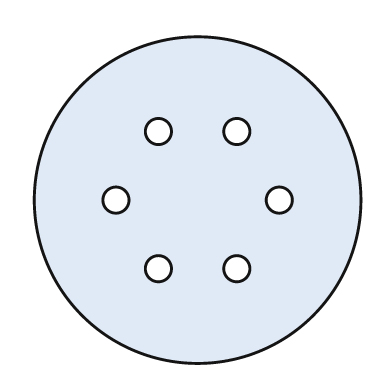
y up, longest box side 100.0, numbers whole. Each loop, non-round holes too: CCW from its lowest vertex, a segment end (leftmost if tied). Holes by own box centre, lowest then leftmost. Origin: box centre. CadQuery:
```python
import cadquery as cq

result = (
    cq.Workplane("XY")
    .moveTo(0.0, 0.0)
    .circle(50.0)
    .moveTo(-12.0, -21.0)
    .circle(4.0)
    .moveTo(12.0, -21.0)
    .circle(4.0)
    .moveTo(-25.0, 0.0)
    .circle(4.0)
    .moveTo(25.0, 0.0)
    .circle(4.0)
    .moveTo(-12.0, 21.0)
    .circle(4.0)
    .moveTo(12.0, 21.0)
    .circle(4.0)
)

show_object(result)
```